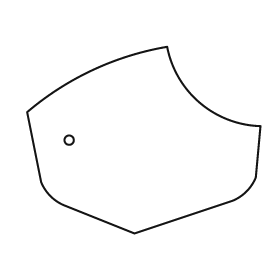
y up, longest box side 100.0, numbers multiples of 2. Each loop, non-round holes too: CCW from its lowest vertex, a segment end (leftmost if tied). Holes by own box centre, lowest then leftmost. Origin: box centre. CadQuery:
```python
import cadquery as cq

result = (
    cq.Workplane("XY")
    .moveTo(-4.0, -40.0)
    .lineTo(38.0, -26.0)
    .threePointArc((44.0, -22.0), (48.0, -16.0))
    .lineTo(50.0, 6.0)
    .threePointArc((24.0, 16.0), (10.0, 40.0))
    .threePointArc((-22.0, 30.0), (-50.0, 12.0))
    .lineTo(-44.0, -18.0)
    .threePointArc((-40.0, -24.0), (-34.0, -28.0))
    .close()
    .moveTo(-32.0, 0.0)
    .circle(2.0)
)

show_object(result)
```